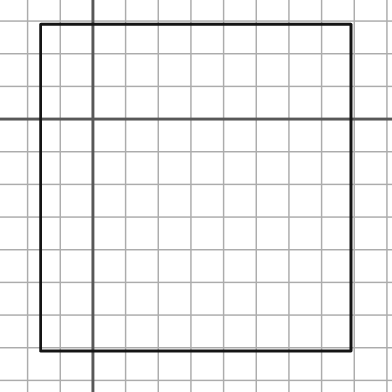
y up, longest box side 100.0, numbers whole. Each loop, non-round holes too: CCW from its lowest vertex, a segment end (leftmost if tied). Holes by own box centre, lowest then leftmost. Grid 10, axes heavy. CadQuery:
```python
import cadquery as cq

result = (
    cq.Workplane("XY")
    .moveTo(-16.0, -71.0)
    .lineTo(79.0, -71.0)
    .lineTo(79.0, 29.0)
    .lineTo(-16.0, 29.0)
    .close()
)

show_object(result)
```